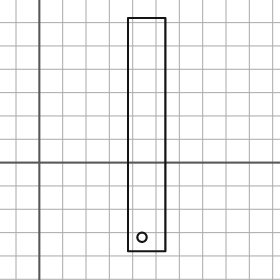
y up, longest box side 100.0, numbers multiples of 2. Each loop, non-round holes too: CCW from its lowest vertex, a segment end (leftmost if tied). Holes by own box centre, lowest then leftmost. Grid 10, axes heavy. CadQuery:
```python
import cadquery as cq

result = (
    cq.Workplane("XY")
    .moveTo(38.0, -38.0)
    .lineTo(54.0, -38.0)
    .lineTo(54.0, 62.0)
    .lineTo(38.0, 62.0)
    .close()
    .moveTo(44.0, -32.0)
    .circle(2.0)
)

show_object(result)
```